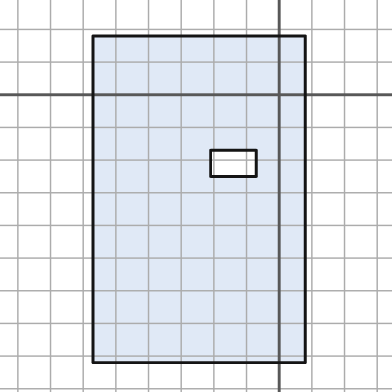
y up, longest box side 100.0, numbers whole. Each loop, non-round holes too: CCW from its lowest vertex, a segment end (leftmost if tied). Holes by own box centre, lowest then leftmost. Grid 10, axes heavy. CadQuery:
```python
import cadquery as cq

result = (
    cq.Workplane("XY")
    .moveTo(-57.0, -82.0)
    .lineTo(8.0, -82.0)
    .lineTo(8.0, 18.0)
    .lineTo(-57.0, 18.0)
    .close()
    .moveTo(-21.0, -25.0)
    .lineTo(-7.0, -25.0)
    .lineTo(-7.0, -17.0)
    .lineTo(-21.0, -17.0)
    .close()
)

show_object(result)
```